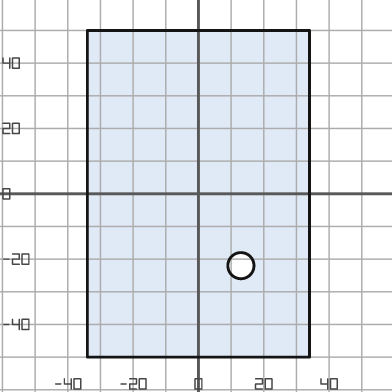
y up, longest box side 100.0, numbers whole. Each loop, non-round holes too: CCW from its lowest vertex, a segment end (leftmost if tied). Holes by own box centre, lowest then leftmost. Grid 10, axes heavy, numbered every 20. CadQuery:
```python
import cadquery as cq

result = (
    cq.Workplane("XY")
    .moveTo(-34.0, -50.0)
    .lineTo(34.0, -50.0)
    .lineTo(34.0, 50.0)
    .lineTo(-34.0, 50.0)
    .close()
    .moveTo(13.0, -22.0)
    .circle(4.0)
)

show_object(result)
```